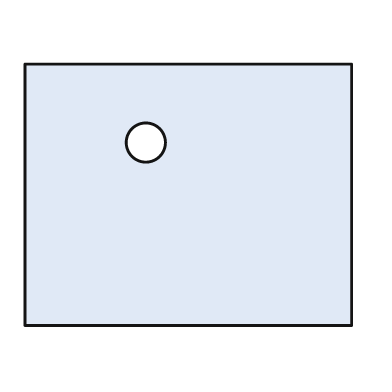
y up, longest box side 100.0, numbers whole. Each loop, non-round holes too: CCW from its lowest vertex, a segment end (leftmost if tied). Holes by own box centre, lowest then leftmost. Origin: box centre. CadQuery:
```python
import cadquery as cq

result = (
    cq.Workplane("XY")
    .moveTo(-50.0, -40.0)
    .lineTo(50.0, -40.0)
    .lineTo(50.0, 40.0)
    .lineTo(-50.0, 40.0)
    .close()
    .moveTo(-13.0, 16.0)
    .circle(6.0)
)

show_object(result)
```